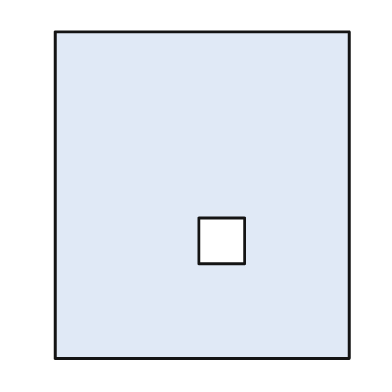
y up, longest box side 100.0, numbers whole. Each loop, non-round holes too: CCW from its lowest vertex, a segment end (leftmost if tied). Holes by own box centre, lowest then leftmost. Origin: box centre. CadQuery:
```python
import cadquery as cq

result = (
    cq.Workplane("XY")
    .moveTo(-45.0, -50.0)
    .lineTo(45.0, -50.0)
    .lineTo(45.0, 50.0)
    .lineTo(-45.0, 50.0)
    .close()
    .moveTo(-1.0, -21.0)
    .lineTo(13.0, -21.0)
    .lineTo(13.0, -7.0)
    .lineTo(-1.0, -7.0)
    .close()
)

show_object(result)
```